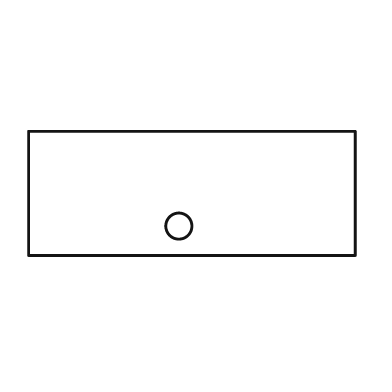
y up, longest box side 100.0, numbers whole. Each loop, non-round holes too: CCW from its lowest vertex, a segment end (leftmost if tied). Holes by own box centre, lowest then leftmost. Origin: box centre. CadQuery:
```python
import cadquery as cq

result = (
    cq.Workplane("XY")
    .moveTo(-50.0, -19.0)
    .lineTo(50.0, -19.0)
    .lineTo(50.0, 19.0)
    .lineTo(-50.0, 19.0)
    .close()
    .moveTo(-4.0, -10.0)
    .circle(4.0)
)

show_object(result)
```